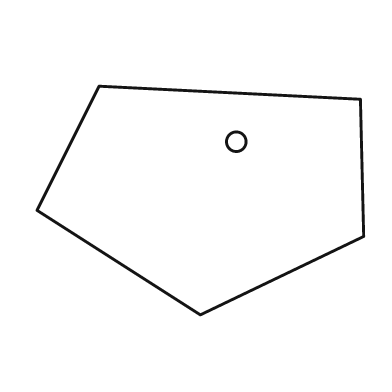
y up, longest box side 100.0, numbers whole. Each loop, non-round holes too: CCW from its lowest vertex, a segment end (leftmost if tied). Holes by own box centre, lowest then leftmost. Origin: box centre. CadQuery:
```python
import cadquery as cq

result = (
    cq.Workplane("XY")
    .moveTo(0.0, -35.0)
    .lineTo(50.0, -11.0)
    .lineTo(49.0, 31.0)
    .lineTo(-31.0, 35.0)
    .lineTo(-50.0, -3.0)
    .close()
    .moveTo(11.0, 18.0)
    .circle(3.0)
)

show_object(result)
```